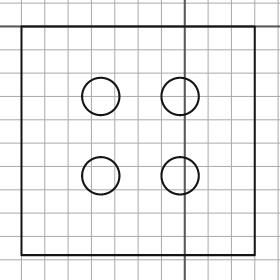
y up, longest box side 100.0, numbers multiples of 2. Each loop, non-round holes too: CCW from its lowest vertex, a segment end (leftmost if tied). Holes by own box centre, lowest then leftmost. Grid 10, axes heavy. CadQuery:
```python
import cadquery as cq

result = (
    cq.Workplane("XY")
    .moveTo(-70.0, -98.0)
    .lineTo(30.0, -98.0)
    .lineTo(30.0, 0.0)
    .lineTo(-70.0, 0.0)
    .close()
    .moveTo(-36.0, -64.0)
    .circle(8.0)
    .moveTo(-2.0, -64.0)
    .circle(8.0)
    .moveTo(-36.0, -30.0)
    .circle(8.0)
    .moveTo(-2.0, -30.0)
    .circle(8.0)
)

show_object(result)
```